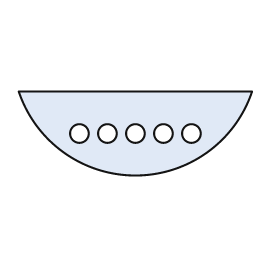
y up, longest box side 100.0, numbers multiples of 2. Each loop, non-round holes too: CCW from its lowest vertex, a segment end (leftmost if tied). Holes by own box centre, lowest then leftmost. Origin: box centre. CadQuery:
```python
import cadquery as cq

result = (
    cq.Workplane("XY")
    .moveTo(-50.0, 18.0)
    .threePointArc((0.0, -18.0), (50.0, 18.0))
    .close()
    .moveTo(-24.0, 0.0)
    .circle(4.0)
    .moveTo(-12.0, 0.0)
    .circle(4.0)
    .moveTo(0.0, 0.0)
    .circle(4.0)
    .moveTo(12.0, 0.0)
    .circle(4.0)
    .moveTo(24.0, 0.0)
    .circle(4.0)
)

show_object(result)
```